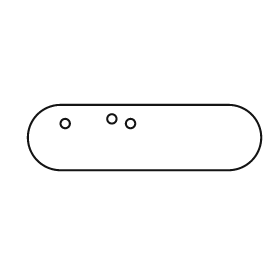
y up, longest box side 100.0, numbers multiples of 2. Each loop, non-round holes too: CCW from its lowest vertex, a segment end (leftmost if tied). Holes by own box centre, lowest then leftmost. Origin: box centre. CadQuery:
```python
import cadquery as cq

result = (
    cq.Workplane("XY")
    .moveTo(-36.0, -14.0)
    .lineTo(36.0, -14.0)
    .threePointArc((50.0, 0.0), (36.0, 14.0))
    .lineTo(-36.0, 14.0)
    .threePointArc((-50.0, 0.0), (-36.0, -14.0))
    .close()
    .moveTo(-34.0, 6.0)
    .circle(2.0)
    .moveTo(-6.0, 6.0)
    .circle(2.0)
    .moveTo(-14.0, 8.0)
    .circle(2.0)
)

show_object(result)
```